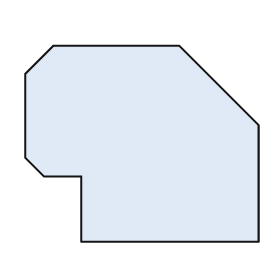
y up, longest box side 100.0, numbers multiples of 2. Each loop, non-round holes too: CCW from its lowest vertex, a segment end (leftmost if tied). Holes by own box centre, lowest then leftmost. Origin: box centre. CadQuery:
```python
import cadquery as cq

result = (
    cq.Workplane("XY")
    .moveTo(-26.0, -42.0)
    .lineTo(50.0, -42.0)
    .lineTo(50.0, 8.0)
    .lineTo(16.0, 42.0)
    .lineTo(-38.0, 42.0)
    .lineTo(-50.0, 30.0)
    .lineTo(-50.0, -6.0)
    .lineTo(-42.0, -14.0)
    .lineTo(-26.0, -14.0)
    .close()
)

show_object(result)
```